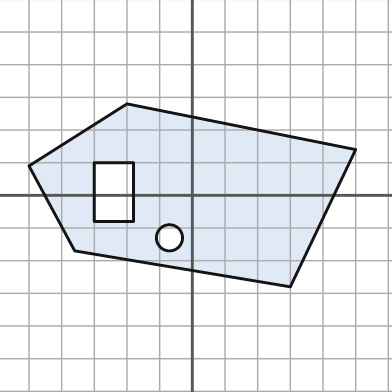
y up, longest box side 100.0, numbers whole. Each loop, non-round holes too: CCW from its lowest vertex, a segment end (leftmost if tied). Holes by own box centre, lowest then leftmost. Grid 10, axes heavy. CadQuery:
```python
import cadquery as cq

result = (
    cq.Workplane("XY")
    .moveTo(30.0, -28.0)
    .lineTo(50.0, 14.0)
    .lineTo(-20.0, 28.0)
    .lineTo(-50.0, 9.0)
    .lineTo(-36.0, -17.0)
    .close()
    .moveTo(-7.0, -13.0)
    .circle(4.0)
    .moveTo(-30.0, -8.0)
    .lineTo(-18.0, -8.0)
    .lineTo(-18.0, 10.0)
    .lineTo(-30.0, 10.0)
    .close()
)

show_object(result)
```